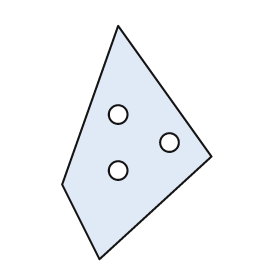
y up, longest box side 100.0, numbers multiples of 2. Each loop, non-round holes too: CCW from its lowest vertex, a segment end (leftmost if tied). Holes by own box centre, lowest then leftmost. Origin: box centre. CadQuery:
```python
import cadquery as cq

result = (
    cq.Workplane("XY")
    .moveTo(-16.0, -50.0)
    .lineTo(32.0, -6.0)
    .lineTo(-8.0, 50.0)
    .lineTo(-32.0, -18.0)
    .close()
    .moveTo(-8.0, -12.0)
    .circle(4.0)
    .moveTo(14.0, 0.0)
    .circle(4.0)
    .moveTo(-8.0, 12.0)
    .circle(4.0)
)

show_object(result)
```